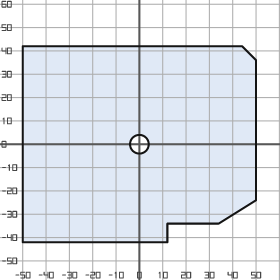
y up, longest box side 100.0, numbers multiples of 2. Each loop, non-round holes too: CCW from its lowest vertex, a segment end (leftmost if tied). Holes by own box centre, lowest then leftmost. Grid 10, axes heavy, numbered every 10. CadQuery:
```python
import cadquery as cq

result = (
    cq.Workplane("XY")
    .moveTo(-50.0, -42.0)
    .lineTo(12.0, -42.0)
    .lineTo(12.0, -34.0)
    .lineTo(34.0, -34.0)
    .lineTo(50.0, -24.0)
    .lineTo(50.0, 36.0)
    .lineTo(44.0, 42.0)
    .lineTo(-50.0, 42.0)
    .close()
    .moveTo(0.0, 0.0)
    .circle(4.0)
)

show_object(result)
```